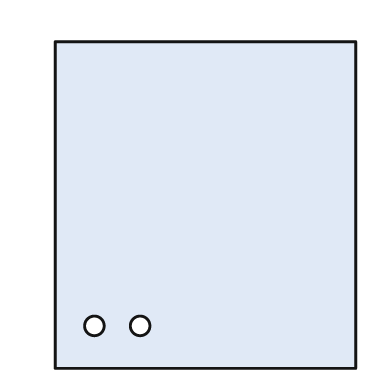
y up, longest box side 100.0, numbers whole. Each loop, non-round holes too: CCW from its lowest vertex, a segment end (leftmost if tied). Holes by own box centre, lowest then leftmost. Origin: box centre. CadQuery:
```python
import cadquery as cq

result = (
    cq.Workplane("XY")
    .moveTo(-46.0, -50.0)
    .lineTo(46.0, -50.0)
    .lineTo(46.0, 50.0)
    .lineTo(-46.0, 50.0)
    .close()
    .moveTo(-34.0, -37.0)
    .circle(3.0)
    .moveTo(-20.0, -37.0)
    .circle(3.0)
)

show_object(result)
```